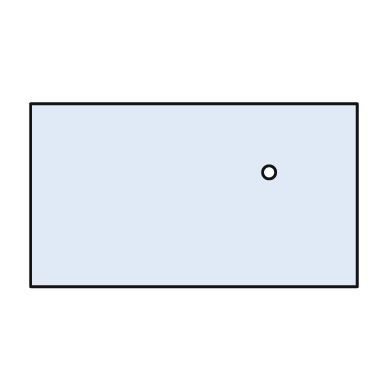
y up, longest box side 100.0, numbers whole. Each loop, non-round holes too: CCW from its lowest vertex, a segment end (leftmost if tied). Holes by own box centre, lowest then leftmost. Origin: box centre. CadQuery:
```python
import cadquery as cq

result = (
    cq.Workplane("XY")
    .moveTo(-50.0, -28.0)
    .lineTo(50.0, -28.0)
    .lineTo(50.0, 28.0)
    .lineTo(-50.0, 28.0)
    .close()
    .moveTo(23.0, 7.0)
    .circle(2.0)
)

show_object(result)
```